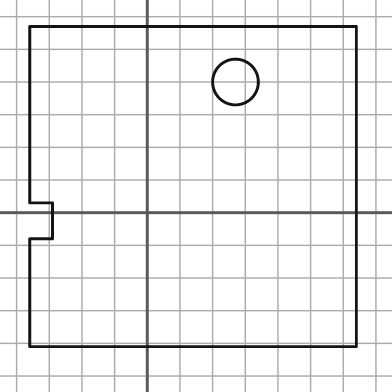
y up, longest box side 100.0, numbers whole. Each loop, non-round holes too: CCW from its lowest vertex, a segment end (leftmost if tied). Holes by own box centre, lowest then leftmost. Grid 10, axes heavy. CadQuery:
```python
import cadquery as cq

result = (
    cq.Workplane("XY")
    .moveTo(-36.0, -41.0)
    .lineTo(64.0, -41.0)
    .lineTo(64.0, 57.0)
    .lineTo(-36.0, 57.0)
    .lineTo(-36.0, 3.0)
    .lineTo(-29.0, 3.0)
    .lineTo(-29.0, -8.0)
    .lineTo(-36.0, -8.0)
    .close()
    .moveTo(27.0, 40.0)
    .circle(7.0)
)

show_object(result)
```